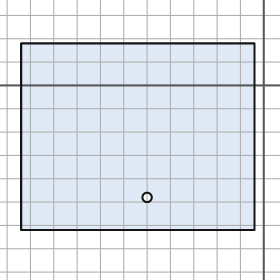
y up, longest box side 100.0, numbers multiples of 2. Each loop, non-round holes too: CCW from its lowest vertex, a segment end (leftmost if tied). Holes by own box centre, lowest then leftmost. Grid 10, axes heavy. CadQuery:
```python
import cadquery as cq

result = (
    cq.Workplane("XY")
    .moveTo(-104.0, -62.0)
    .lineTo(-4.0, -62.0)
    .lineTo(-4.0, 18.0)
    .lineTo(-104.0, 18.0)
    .close()
    .moveTo(-50.0, -48.0)
    .circle(2.0)
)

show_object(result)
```